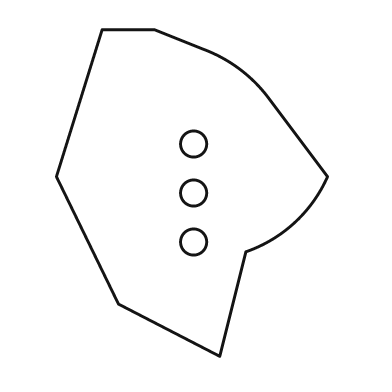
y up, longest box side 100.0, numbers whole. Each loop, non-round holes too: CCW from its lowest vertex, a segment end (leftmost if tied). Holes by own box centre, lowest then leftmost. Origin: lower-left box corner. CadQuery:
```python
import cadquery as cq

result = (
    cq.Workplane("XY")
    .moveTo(50.0, 0.0)
    .lineTo(58.0, 32.0)
    .threePointArc((73.0, 41.0), (83.0, 55.0))
    .lineTo(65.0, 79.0)
    .threePointArc((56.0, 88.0), (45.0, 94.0))
    .lineTo(30.0, 100.0)
    .lineTo(14.0, 100.0)
    .lineTo(0.0, 55.0)
    .lineTo(19.0, 16.0)
    .close()
    .moveTo(42.0, 35.0)
    .circle(4.0)
    .moveTo(42.0, 50.0)
    .circle(4.0)
    .moveTo(42.0, 65.0)
    .circle(4.0)
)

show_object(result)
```